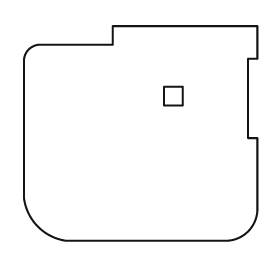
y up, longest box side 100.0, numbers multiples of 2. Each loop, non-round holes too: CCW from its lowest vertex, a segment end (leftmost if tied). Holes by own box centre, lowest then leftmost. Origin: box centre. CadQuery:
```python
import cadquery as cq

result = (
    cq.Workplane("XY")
    .moveTo(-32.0, -46.0)
    .lineTo(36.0, -46.0)
    .threePointArc((46.0, -42.0), (50.0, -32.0))
    .lineTo(50.0, -2.0)
    .lineTo(46.0, -2.0)
    .lineTo(46.0, 32.0)
    .lineTo(50.0, 32.0)
    .lineTo(50.0, 46.0)
    .lineTo(-12.0, 46.0)
    .lineTo(-12.0, 38.0)
    .lineTo(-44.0, 38.0)
    .threePointArc((-48.0, 36.0), (-50.0, 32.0))
    .lineTo(-50.0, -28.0)
    .threePointArc((-44.0, -40.0), (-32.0, -46.0))
    .close()
    .moveTo(10.0, 12.0)
    .lineTo(18.0, 12.0)
    .lineTo(18.0, 20.0)
    .lineTo(10.0, 20.0)
    .close()
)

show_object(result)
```